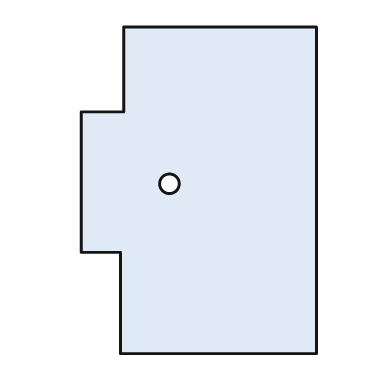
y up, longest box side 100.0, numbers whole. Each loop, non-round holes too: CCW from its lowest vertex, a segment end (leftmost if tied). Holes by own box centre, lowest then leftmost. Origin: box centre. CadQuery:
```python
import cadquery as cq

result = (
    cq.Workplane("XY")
    .moveTo(-24.0, -50.0)
    .lineTo(36.0, -50.0)
    .lineTo(36.0, 50.0)
    .lineTo(-23.0, 50.0)
    .lineTo(-23.0, 24.0)
    .lineTo(-36.0, 24.0)
    .lineTo(-36.0, -19.0)
    .lineTo(-24.0, -19.0)
    .close()
    .moveTo(-9.0, 2.0)
    .circle(3.0)
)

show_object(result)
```